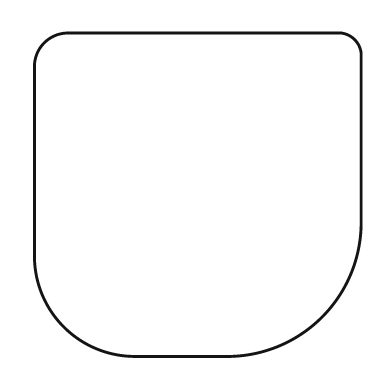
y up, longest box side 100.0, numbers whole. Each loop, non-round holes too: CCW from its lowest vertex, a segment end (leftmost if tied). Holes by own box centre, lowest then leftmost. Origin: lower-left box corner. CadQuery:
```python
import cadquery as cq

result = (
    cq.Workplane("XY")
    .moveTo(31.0, 0.0)
    .lineTo(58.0, 0.0)
    .threePointArc((88.0, 12.0), (100.0, 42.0))
    .lineTo(100.0, 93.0)
    .threePointArc((98.0, 97.0), (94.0, 99.0))
    .lineTo(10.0, 99.0)
    .threePointArc((3.0, 96.0), (0.0, 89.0))
    .lineTo(0.0, 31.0)
    .threePointArc((9.0, 9.0), (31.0, 0.0))
    .close()
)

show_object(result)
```